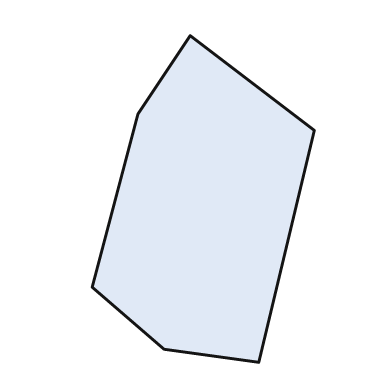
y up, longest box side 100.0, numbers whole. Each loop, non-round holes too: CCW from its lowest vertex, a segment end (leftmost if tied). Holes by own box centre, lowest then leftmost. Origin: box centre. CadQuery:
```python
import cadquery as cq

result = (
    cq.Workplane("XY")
    .moveTo(17.0, -50.0)
    .lineTo(34.0, 21.0)
    .lineTo(-4.0, 50.0)
    .lineTo(-20.0, 26.0)
    .lineTo(-34.0, -27.0)
    .lineTo(-12.0, -46.0)
    .close()
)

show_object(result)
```